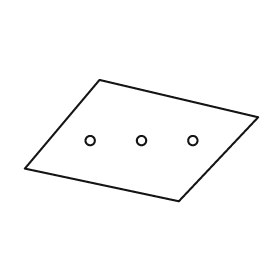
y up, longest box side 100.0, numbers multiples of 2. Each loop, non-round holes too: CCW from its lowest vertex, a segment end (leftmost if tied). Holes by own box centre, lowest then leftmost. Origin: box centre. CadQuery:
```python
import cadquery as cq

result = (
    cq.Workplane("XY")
    .moveTo(16.0, -26.0)
    .lineTo(50.0, 10.0)
    .lineTo(-18.0, 26.0)
    .lineTo(-50.0, -12.0)
    .close()
    .moveTo(-22.0, 0.0)
    .circle(2.0)
    .moveTo(0.0, 0.0)
    .circle(2.0)
    .moveTo(22.0, 0.0)
    .circle(2.0)
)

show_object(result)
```